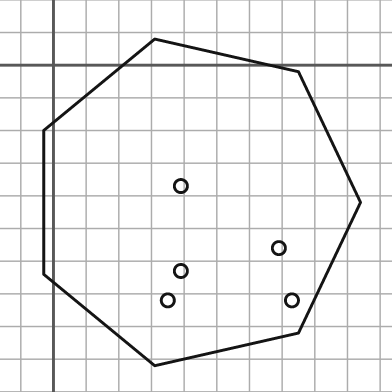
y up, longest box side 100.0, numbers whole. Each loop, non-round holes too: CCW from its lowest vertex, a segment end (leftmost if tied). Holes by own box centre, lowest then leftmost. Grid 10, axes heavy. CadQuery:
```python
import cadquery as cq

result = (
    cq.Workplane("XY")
    .moveTo(31.0, -92.0)
    .lineTo(75.0, -82.0)
    .lineTo(94.0, -42.0)
    .lineTo(75.0, -2.0)
    .lineTo(31.0, 8.0)
    .lineTo(-3.0, -20.0)
    .lineTo(-3.0, -64.0)
    .close()
    .moveTo(35.0, -72.0)
    .circle(2.0)
    .moveTo(73.0, -72.0)
    .circle(2.0)
    .moveTo(39.0, -63.0)
    .circle(2.0)
    .moveTo(69.0, -56.0)
    .circle(2.0)
    .moveTo(39.0, -37.0)
    .circle(2.0)
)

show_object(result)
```